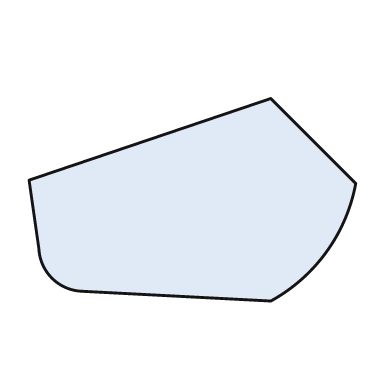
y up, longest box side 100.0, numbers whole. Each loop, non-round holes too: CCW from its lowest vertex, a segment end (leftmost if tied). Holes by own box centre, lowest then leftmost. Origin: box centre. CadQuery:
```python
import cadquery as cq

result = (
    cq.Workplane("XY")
    .moveTo(24.0, -31.0)
    .threePointArc((41.0, -16.0), (50.0, 5.0))
    .lineTo(24.0, 31.0)
    .lineTo(-50.0, 6.0)
    .lineTo(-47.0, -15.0)
    .threePointArc((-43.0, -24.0), (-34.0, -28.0))
    .close()
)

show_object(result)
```